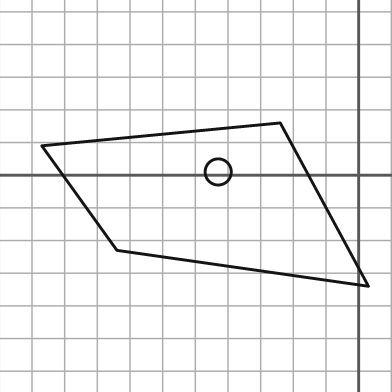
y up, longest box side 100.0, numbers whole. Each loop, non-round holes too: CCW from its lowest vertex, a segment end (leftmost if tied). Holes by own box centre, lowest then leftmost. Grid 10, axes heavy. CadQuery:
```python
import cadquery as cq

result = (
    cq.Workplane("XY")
    .moveTo(3.0, -34.0)
    .lineTo(-24.0, 16.0)
    .lineTo(-97.0, 9.0)
    .lineTo(-74.0, -23.0)
    .close()
    .moveTo(-43.0, 1.0)
    .circle(4.0)
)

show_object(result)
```